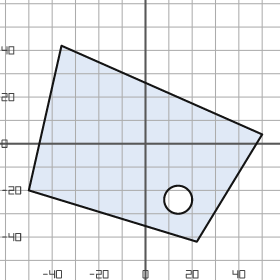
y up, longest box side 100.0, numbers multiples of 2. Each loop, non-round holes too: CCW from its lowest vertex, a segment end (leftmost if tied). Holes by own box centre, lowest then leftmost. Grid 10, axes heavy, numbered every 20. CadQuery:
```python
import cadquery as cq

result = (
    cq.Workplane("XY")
    .moveTo(22.0, -42.0)
    .lineTo(50.0, 4.0)
    .lineTo(-36.0, 42.0)
    .lineTo(-50.0, -20.0)
    .close()
    .moveTo(14.0, -24.0)
    .circle(6.0)
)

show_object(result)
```